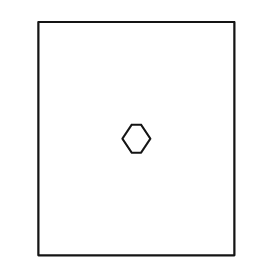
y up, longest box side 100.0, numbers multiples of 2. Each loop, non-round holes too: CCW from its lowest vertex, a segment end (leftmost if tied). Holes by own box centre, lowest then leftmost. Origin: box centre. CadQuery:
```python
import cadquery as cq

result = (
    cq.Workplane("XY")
    .moveTo(-42.0, -50.0)
    .lineTo(42.0, -50.0)
    .lineTo(42.0, 50.0)
    .lineTo(-42.0, 50.0)
    .close()
    .moveTo(-2.0, -6.0)
    .lineTo(2.0, -6.0)
    .lineTo(6.0, 0.0)
    .lineTo(2.0, 6.0)
    .lineTo(-2.0, 6.0)
    .lineTo(-6.0, 0.0)
    .close()
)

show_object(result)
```